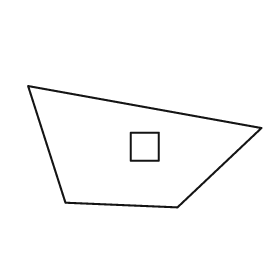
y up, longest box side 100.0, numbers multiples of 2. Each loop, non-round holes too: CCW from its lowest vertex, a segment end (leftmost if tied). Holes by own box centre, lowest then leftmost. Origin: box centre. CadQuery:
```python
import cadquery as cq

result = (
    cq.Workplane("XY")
    .moveTo(14.0, -26.0)
    .lineTo(50.0, 8.0)
    .lineTo(-50.0, 26.0)
    .lineTo(-34.0, -24.0)
    .close()
    .moveTo(-6.0, -6.0)
    .lineTo(6.0, -6.0)
    .lineTo(6.0, 6.0)
    .lineTo(-6.0, 6.0)
    .close()
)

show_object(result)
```